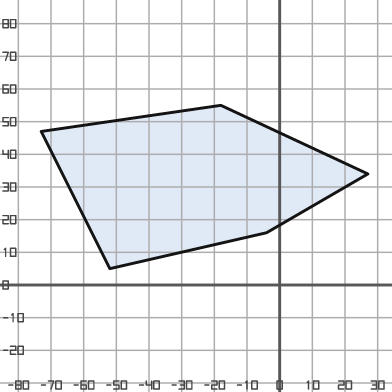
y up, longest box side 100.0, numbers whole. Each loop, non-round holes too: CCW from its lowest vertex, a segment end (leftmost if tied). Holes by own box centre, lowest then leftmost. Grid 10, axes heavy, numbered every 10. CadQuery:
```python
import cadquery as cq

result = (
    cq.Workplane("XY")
    .moveTo(-52.0, 5.0)
    .lineTo(-4.0, 16.0)
    .lineTo(27.0, 34.0)
    .lineTo(-18.0, 55.0)
    .lineTo(-73.0, 47.0)
    .close()
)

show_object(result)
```